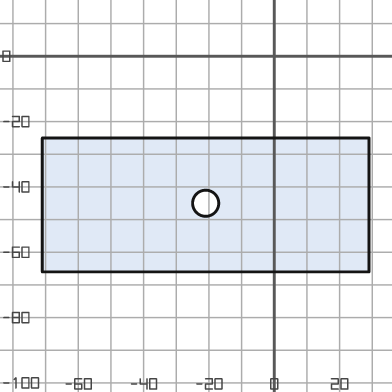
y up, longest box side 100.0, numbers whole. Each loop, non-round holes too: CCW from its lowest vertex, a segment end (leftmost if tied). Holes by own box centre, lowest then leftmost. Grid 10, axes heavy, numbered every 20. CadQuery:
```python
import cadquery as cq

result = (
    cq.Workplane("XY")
    .moveTo(-71.0, -66.0)
    .lineTo(29.0, -66.0)
    .lineTo(29.0, -25.0)
    .lineTo(-71.0, -25.0)
    .close()
    .moveTo(-21.0, -45.0)
    .circle(4.0)
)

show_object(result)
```